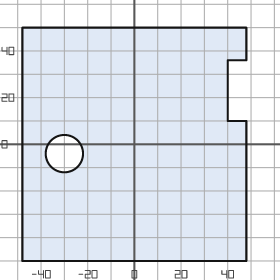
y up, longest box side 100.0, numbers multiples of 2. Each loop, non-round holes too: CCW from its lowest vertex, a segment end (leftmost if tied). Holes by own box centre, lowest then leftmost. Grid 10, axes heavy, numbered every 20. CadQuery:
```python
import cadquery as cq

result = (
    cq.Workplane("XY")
    .moveTo(-48.0, -50.0)
    .lineTo(48.0, -50.0)
    .lineTo(48.0, 10.0)
    .lineTo(40.0, 10.0)
    .lineTo(40.0, 36.0)
    .lineTo(48.0, 36.0)
    .lineTo(48.0, 50.0)
    .lineTo(-48.0, 50.0)
    .close()
    .moveTo(-30.0, -4.0)
    .circle(8.0)
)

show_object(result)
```